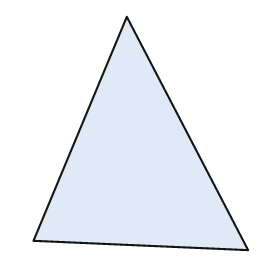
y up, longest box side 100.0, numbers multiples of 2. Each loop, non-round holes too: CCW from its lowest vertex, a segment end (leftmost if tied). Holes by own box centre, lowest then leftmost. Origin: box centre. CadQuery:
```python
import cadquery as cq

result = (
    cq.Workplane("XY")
    .moveTo(46.0, -50.0)
    .lineTo(-6.0, 50.0)
    .lineTo(-46.0, -46.0)
    .close()
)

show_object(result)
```